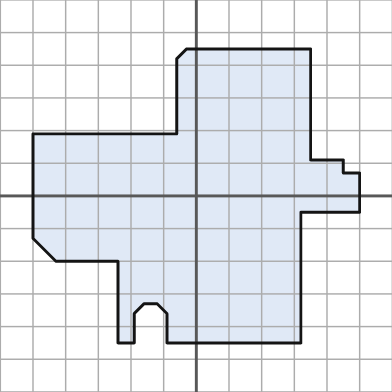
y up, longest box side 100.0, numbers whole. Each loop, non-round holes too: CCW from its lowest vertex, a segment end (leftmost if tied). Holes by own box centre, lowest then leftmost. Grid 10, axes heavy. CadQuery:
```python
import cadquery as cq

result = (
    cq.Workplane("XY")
    .moveTo(-24.0, -45.0)
    .lineTo(-19.0, -45.0)
    .lineTo(-19.0, -36.0)
    .lineTo(-16.0, -33.0)
    .lineTo(-12.0, -33.0)
    .lineTo(-9.0, -36.0)
    .lineTo(-9.0, -45.0)
    .lineTo(32.0, -45.0)
    .lineTo(32.0, -5.0)
    .lineTo(50.0, -5.0)
    .lineTo(50.0, 7.0)
    .lineTo(45.0, 7.0)
    .lineTo(45.0, 11.0)
    .lineTo(35.0, 11.0)
    .lineTo(35.0, 45.0)
    .lineTo(-3.0, 45.0)
    .lineTo(-6.0, 42.0)
    .lineTo(-6.0, 19.0)
    .lineTo(-50.0, 19.0)
    .lineTo(-50.0, -13.0)
    .lineTo(-43.0, -20.0)
    .lineTo(-24.0, -20.0)
    .close()
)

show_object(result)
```